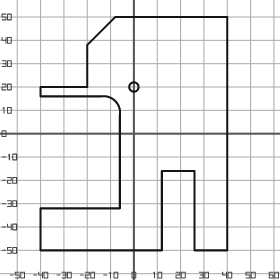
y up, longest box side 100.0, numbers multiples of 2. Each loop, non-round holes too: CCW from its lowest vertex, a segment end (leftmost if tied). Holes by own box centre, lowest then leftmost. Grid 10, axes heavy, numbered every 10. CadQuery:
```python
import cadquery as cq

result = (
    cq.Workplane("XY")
    .moveTo(-40.0, -50.0)
    .lineTo(12.0, -50.0)
    .lineTo(12.0, -16.0)
    .lineTo(26.0, -16.0)
    .lineTo(26.0, -50.0)
    .lineTo(40.0, -50.0)
    .lineTo(40.0, 50.0)
    .lineTo(-8.0, 50.0)
    .lineTo(-20.0, 38.0)
    .lineTo(-20.0, 20.0)
    .lineTo(-40.0, 20.0)
    .lineTo(-40.0, 16.0)
    .lineTo(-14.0, 16.0)
    .threePointArc((-8.0, 14.0), (-6.0, 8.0))
    .lineTo(-6.0, -32.0)
    .lineTo(-40.0, -32.0)
    .close()
    .moveTo(0.0, 20.0)
    .circle(2.0)
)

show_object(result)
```